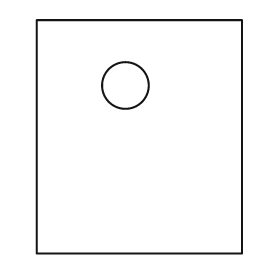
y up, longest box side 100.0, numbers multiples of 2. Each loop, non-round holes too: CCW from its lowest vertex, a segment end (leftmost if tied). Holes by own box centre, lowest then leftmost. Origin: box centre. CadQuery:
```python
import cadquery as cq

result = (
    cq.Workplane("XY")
    .moveTo(-44.0, -50.0)
    .lineTo(44.0, -50.0)
    .lineTo(44.0, 50.0)
    .lineTo(-44.0, 50.0)
    .close()
    .moveTo(-6.0, 22.0)
    .circle(10.0)
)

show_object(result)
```